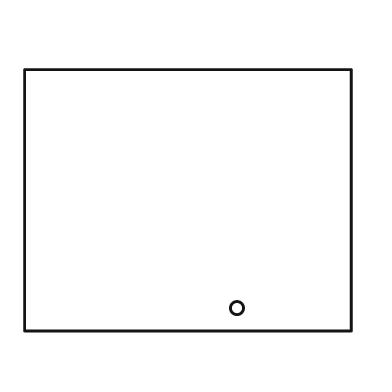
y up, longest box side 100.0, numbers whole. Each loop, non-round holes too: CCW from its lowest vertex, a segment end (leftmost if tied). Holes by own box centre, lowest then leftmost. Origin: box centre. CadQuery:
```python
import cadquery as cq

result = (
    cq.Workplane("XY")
    .moveTo(-50.0, -40.0)
    .lineTo(50.0, -40.0)
    .lineTo(50.0, 40.0)
    .lineTo(-50.0, 40.0)
    .close()
    .moveTo(15.0, -33.0)
    .circle(2.0)
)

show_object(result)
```